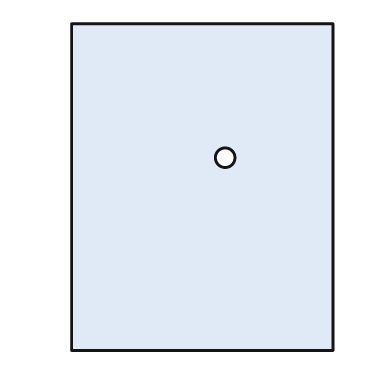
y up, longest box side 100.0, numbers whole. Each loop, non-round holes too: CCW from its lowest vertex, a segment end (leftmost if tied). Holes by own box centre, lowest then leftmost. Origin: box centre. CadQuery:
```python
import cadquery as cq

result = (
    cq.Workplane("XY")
    .moveTo(-40.0, -50.0)
    .lineTo(40.0, -50.0)
    .lineTo(40.0, 50.0)
    .lineTo(-40.0, 50.0)
    .close()
    .moveTo(7.0, 9.0)
    .circle(3.0)
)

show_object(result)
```